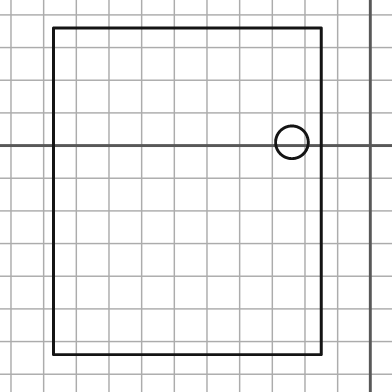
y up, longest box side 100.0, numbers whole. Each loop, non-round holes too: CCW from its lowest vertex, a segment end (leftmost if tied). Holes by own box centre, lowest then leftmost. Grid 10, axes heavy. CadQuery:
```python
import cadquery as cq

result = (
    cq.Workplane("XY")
    .moveTo(-97.0, -64.0)
    .lineTo(-15.0, -64.0)
    .lineTo(-15.0, 36.0)
    .lineTo(-97.0, 36.0)
    .close()
    .moveTo(-24.0, 1.0)
    .circle(5.0)
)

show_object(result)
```